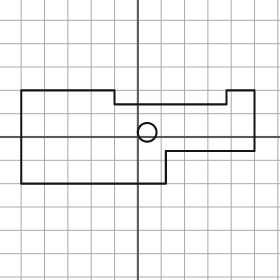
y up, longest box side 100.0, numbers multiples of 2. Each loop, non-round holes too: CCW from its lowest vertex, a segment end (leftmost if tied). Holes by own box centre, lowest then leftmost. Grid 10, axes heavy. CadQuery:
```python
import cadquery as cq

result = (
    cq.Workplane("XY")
    .moveTo(-50.0, -20.0)
    .lineTo(12.0, -20.0)
    .lineTo(12.0, -6.0)
    .lineTo(50.0, -6.0)
    .lineTo(50.0, 20.0)
    .lineTo(38.0, 20.0)
    .lineTo(38.0, 14.0)
    .lineTo(-10.0, 14.0)
    .lineTo(-10.0, 20.0)
    .lineTo(-50.0, 20.0)
    .close()
    .moveTo(4.0, 2.0)
    .circle(4.0)
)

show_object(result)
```